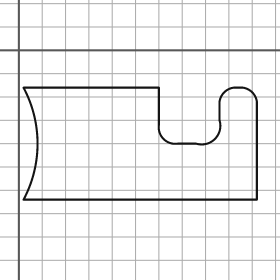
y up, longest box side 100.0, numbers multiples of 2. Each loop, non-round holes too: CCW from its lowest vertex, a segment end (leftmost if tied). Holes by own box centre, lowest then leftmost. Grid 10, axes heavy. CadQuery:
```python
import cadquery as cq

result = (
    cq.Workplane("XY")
    .moveTo(2.0, -64.0)
    .lineTo(102.0, -64.0)
    .lineTo(102.0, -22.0)
    .threePointArc((100.0, -18.0), (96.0, -16.0))
    .lineTo(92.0, -16.0)
    .threePointArc((88.0, -18.0), (86.0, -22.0))
    .lineTo(86.0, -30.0)
    .threePointArc((84.0, -38.0), (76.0, -40.0))
    .lineTo(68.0, -40.0)
    .threePointArc((62.0, -38.0), (60.0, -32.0))
    .lineTo(60.0, -16.0)
    .lineTo(2.0, -16.0)
    .threePointArc((8.0, -40.0), (2.0, -64.0))
    .close()
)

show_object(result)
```